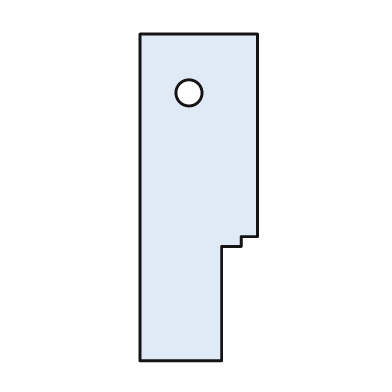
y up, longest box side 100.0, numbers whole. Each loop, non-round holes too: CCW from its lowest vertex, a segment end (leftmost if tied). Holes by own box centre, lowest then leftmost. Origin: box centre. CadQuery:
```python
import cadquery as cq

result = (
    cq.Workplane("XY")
    .moveTo(-18.0, -50.0)
    .lineTo(7.0, -50.0)
    .lineTo(7.0, -15.0)
    .lineTo(13.0, -15.0)
    .lineTo(13.0, -12.0)
    .lineTo(18.0, -12.0)
    .lineTo(18.0, 50.0)
    .lineTo(-18.0, 50.0)
    .close()
    .moveTo(-3.0, 32.0)
    .circle(4.0)
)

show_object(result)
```